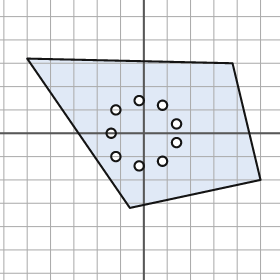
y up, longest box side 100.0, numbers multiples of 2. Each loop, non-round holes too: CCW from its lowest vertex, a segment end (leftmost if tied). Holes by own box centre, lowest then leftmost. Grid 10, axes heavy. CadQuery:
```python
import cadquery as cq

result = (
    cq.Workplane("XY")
    .moveTo(-6.0, -32.0)
    .lineTo(50.0, -20.0)
    .lineTo(38.0, 30.0)
    .lineTo(-50.0, 32.0)
    .close()
    .moveTo(-2.0, -14.0)
    .circle(2.0)
    .moveTo(8.0, -12.0)
    .circle(2.0)
    .moveTo(-12.0, -10.0)
    .circle(2.0)
    .moveTo(14.0, -4.0)
    .circle(2.0)
    .moveTo(-14.0, 0.0)
    .circle(2.0)
    .moveTo(14.0, 4.0)
    .circle(2.0)
    .moveTo(-12.0, 10.0)
    .circle(2.0)
    .moveTo(8.0, 12.0)
    .circle(2.0)
    .moveTo(-2.0, 14.0)
    .circle(2.0)
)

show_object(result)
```